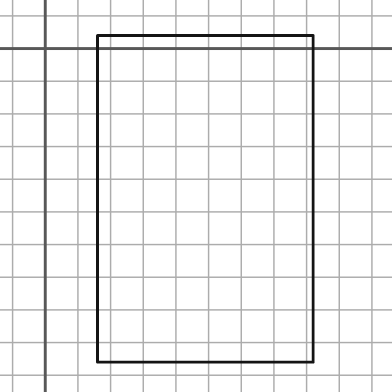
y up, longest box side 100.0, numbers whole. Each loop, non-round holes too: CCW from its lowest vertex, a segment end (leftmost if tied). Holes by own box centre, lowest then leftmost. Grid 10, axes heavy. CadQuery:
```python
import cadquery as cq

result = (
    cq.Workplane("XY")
    .moveTo(16.0, -96.0)
    .lineTo(82.0, -96.0)
    .lineTo(82.0, 4.0)
    .lineTo(16.0, 4.0)
    .close()
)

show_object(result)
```